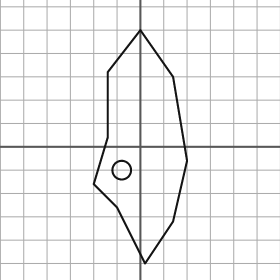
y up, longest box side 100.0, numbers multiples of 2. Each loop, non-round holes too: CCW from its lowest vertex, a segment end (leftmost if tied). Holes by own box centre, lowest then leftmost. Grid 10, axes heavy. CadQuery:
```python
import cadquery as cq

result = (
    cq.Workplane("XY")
    .moveTo(2.0, -50.0)
    .lineTo(14.0, -32.0)
    .lineTo(20.0, -6.0)
    .lineTo(14.0, 30.0)
    .lineTo(0.0, 50.0)
    .lineTo(-14.0, 32.0)
    .lineTo(-14.0, 4.0)
    .lineTo(-20.0, -16.0)
    .lineTo(-10.0, -26.0)
    .close()
    .moveTo(-8.0, -10.0)
    .circle(4.0)
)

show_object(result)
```